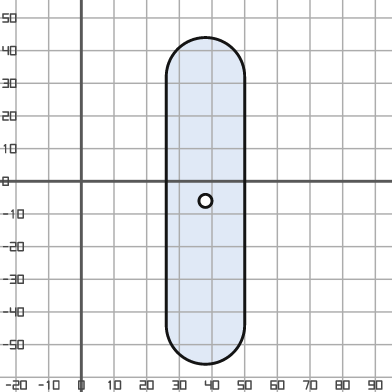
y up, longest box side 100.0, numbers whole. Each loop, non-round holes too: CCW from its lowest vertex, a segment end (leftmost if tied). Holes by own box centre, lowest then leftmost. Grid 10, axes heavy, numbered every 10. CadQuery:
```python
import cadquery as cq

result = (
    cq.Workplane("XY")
    .moveTo(26.0, -44.0)
    .threePointArc((38.0, -56.0), (50.0, -44.0))
    .lineTo(50.0, 32.0)
    .threePointArc((38.0, 44.0), (26.0, 32.0))
    .close()
    .moveTo(38.0, -6.0)
    .circle(2.0)
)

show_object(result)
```